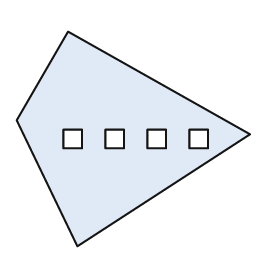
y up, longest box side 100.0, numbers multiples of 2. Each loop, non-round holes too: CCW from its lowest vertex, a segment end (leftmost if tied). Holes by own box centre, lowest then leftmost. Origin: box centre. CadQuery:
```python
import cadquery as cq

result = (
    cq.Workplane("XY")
    .moveTo(-24.0, -46.0)
    .lineTo(50.0, 2.0)
    .lineTo(-28.0, 46.0)
    .lineTo(-50.0, 8.0)
    .close()
    .moveTo(-30.0, -4.0)
    .lineTo(-22.0, -4.0)
    .lineTo(-22.0, 4.0)
    .lineTo(-30.0, 4.0)
    .close()
    .moveTo(-12.0, -4.0)
    .lineTo(-4.0, -4.0)
    .lineTo(-4.0, 4.0)
    .lineTo(-12.0, 4.0)
    .close()
    .moveTo(6.0, -4.0)
    .lineTo(14.0, -4.0)
    .lineTo(14.0, 4.0)
    .lineTo(6.0, 4.0)
    .close()
    .moveTo(24.0, -4.0)
    .lineTo(32.0, -4.0)
    .lineTo(32.0, 4.0)
    .lineTo(24.0, 4.0)
    .close()
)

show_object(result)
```